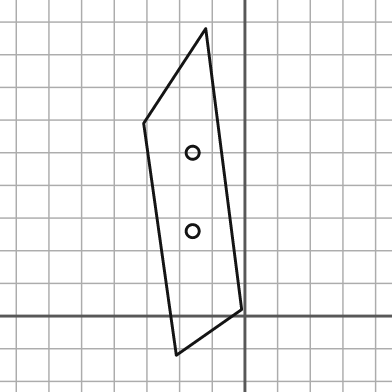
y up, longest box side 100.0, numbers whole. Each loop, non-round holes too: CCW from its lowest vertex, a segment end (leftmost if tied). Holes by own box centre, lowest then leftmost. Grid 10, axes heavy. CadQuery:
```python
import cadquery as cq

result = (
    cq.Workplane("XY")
    .moveTo(-21.0, -12.0)
    .lineTo(-1.0, 2.0)
    .lineTo(-12.0, 88.0)
    .lineTo(-31.0, 59.0)
    .close()
    .moveTo(-16.0, 26.0)
    .circle(2.0)
    .moveTo(-16.0, 50.0)
    .circle(2.0)
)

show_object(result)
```